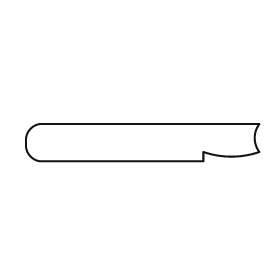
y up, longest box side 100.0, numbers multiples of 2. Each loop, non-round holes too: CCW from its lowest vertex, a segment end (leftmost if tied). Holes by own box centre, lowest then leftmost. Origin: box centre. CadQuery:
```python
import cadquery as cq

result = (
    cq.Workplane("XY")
    .moveTo(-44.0, -8.0)
    .lineTo(26.0, -8.0)
    .lineTo(26.0, -4.0)
    .threePointArc((38.0, -6.0), (50.0, -4.0))
    .threePointArc((48.0, 2.0), (50.0, 8.0))
    .lineTo(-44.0, 8.0)
    .threePointArc((-48.0, 6.0), (-50.0, 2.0))
    .lineTo(-50.0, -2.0)
    .threePointArc((-48.0, -6.0), (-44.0, -8.0))
    .close()
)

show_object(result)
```